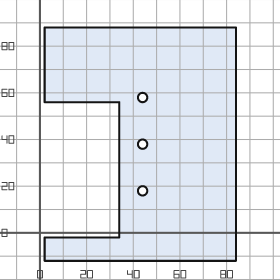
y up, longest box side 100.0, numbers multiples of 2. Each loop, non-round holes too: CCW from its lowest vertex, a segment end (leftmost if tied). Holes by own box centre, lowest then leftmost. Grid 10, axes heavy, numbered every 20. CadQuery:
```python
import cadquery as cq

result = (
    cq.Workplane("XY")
    .moveTo(2.0, -12.0)
    .lineTo(84.0, -12.0)
    .lineTo(84.0, 88.0)
    .lineTo(2.0, 88.0)
    .lineTo(2.0, 56.0)
    .lineTo(34.0, 56.0)
    .lineTo(34.0, -2.0)
    .lineTo(2.0, -2.0)
    .close()
    .moveTo(44.0, 18.0)
    .circle(2.0)
    .moveTo(44.0, 38.0)
    .circle(2.0)
    .moveTo(44.0, 58.0)
    .circle(2.0)
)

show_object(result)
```